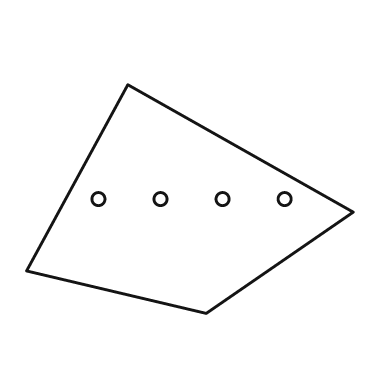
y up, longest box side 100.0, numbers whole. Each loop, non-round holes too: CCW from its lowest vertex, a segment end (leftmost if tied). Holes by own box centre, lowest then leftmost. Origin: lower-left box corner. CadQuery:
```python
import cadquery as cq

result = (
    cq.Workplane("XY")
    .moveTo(55.0, 0.0)
    .lineTo(100.0, 31.0)
    .lineTo(31.0, 70.0)
    .lineTo(0.0, 13.0)
    .close()
    .moveTo(22.0, 35.0)
    .circle(2.0)
    .moveTo(41.0, 35.0)
    .circle(2.0)
    .moveTo(60.0, 35.0)
    .circle(2.0)
    .moveTo(79.0, 35.0)
    .circle(2.0)
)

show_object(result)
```